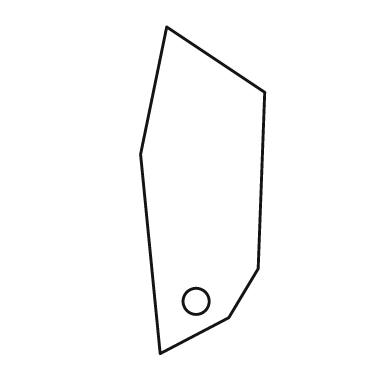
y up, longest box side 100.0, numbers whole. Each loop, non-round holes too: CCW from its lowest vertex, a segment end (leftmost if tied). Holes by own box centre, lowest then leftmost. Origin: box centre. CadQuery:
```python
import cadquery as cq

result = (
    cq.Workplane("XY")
    .moveTo(-13.0, -50.0)
    .lineTo(8.0, -39.0)
    .lineTo(17.0, -24.0)
    .lineTo(19.0, 30.0)
    .lineTo(-11.0, 50.0)
    .lineTo(-19.0, 11.0)
    .close()
    .moveTo(-2.0, -34.0)
    .circle(4.0)
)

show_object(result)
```